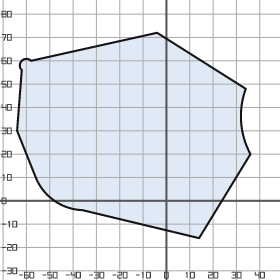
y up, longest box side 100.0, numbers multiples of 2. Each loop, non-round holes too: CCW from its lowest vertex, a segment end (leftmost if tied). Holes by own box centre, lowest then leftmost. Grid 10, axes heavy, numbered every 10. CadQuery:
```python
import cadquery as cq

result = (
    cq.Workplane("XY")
    .moveTo(14.0, -16.0)
    .lineTo(36.0, 20.0)
    .threePointArc((32.0, 34.0), (34.0, 48.0))
    .lineTo(-4.0, 72.0)
    .lineTo(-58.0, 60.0)
    .threePointArc((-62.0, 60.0), (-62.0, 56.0))
    .lineTo(-64.0, 30.0)
    .lineTo(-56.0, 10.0)
    .threePointArc((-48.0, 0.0), (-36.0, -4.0))
    .close()
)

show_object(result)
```